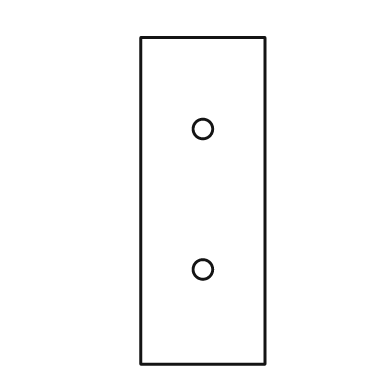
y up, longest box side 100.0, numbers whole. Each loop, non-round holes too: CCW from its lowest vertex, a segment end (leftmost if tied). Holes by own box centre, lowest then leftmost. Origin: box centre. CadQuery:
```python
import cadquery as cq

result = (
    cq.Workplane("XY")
    .moveTo(-19.0, -50.0)
    .lineTo(19.0, -50.0)
    .lineTo(19.0, 50.0)
    .lineTo(-19.0, 50.0)
    .close()
    .moveTo(0.0, -21.0)
    .circle(3.0)
    .moveTo(0.0, 22.0)
    .circle(3.0)
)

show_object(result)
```